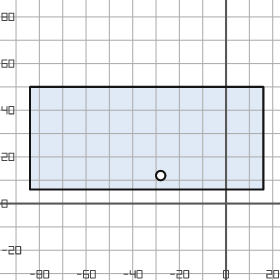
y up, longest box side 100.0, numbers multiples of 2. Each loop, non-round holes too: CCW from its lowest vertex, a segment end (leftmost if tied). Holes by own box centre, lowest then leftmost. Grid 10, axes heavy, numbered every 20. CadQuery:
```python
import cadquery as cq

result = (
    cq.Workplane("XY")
    .moveTo(-84.0, 6.0)
    .lineTo(16.0, 6.0)
    .lineTo(16.0, 50.0)
    .lineTo(-84.0, 50.0)
    .close()
    .moveTo(-28.0, 12.0)
    .circle(2.0)
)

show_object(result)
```